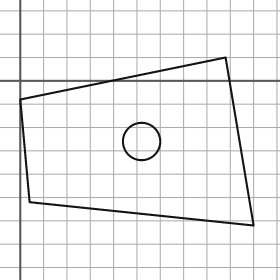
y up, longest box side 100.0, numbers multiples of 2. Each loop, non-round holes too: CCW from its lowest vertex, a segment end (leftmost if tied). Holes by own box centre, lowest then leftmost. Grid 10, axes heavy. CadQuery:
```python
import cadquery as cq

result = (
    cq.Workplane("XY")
    .moveTo(100.0, -62.0)
    .lineTo(88.0, 10.0)
    .lineTo(0.0, -8.0)
    .lineTo(4.0, -52.0)
    .close()
    .moveTo(52.0, -26.0)
    .circle(8.0)
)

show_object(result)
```